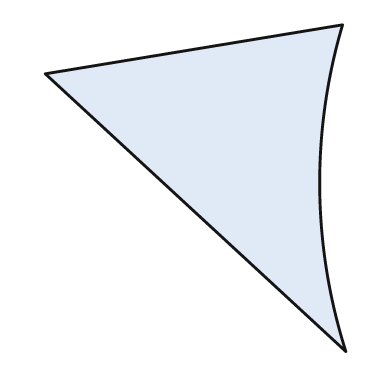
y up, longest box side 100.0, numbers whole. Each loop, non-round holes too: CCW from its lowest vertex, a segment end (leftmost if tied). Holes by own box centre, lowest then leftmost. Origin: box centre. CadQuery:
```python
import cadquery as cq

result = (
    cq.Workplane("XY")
    .moveTo(46.0, -50.0)
    .threePointArc((38.0, 0.0), (45.0, 50.0))
    .lineTo(-46.0, 35.0)
    .close()
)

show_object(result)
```